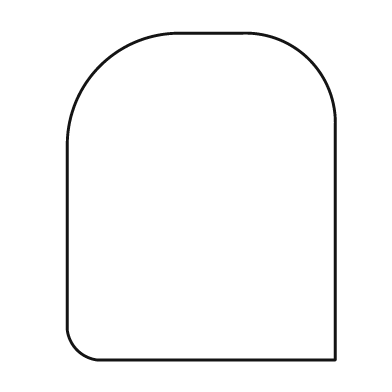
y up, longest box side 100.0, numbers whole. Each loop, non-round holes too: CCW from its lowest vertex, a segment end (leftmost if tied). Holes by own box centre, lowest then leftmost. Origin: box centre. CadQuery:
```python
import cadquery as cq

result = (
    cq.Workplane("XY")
    .moveTo(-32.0, -50.0)
    .lineTo(41.0, -50.0)
    .lineTo(41.0, 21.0)
    .threePointArc((33.0, 42.0), (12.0, 50.0))
    .lineTo(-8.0, 50.0)
    .threePointArc((-31.0, 40.0), (-41.0, 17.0))
    .lineTo(-41.0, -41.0)
    .threePointArc((-38.0, -47.0), (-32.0, -50.0))
    .close()
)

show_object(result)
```